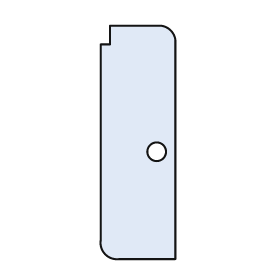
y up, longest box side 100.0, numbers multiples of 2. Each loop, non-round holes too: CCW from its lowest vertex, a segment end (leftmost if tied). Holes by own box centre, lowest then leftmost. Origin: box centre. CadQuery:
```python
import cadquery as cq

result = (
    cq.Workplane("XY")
    .moveTo(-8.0, -50.0)
    .lineTo(16.0, -50.0)
    .lineTo(16.0, 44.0)
    .threePointArc((14.0, 48.0), (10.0, 50.0))
    .lineTo(-12.0, 50.0)
    .lineTo(-12.0, 42.0)
    .lineTo(-16.0, 42.0)
    .lineTo(-16.0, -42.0)
    .threePointArc((-14.0, -48.0), (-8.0, -50.0))
    .close()
    .moveTo(8.0, -4.0)
    .circle(4.0)
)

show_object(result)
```